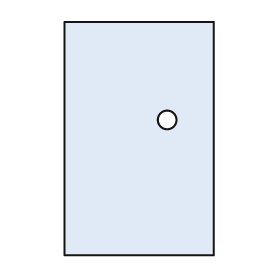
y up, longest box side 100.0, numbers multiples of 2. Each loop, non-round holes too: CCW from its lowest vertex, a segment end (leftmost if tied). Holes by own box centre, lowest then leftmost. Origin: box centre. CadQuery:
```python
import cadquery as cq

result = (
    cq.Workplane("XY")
    .moveTo(-32.0, -50.0)
    .lineTo(32.0, -50.0)
    .lineTo(32.0, 50.0)
    .lineTo(-32.0, 50.0)
    .close()
    .moveTo(12.0, 8.0)
    .circle(4.0)
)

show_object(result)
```